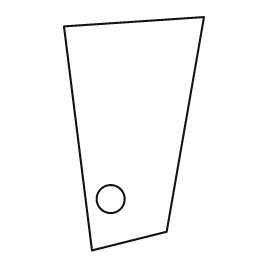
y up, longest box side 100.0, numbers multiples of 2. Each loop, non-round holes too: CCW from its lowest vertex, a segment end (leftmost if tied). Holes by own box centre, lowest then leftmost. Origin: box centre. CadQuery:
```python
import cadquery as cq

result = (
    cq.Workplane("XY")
    .moveTo(-18.0, -50.0)
    .lineTo(14.0, -42.0)
    .lineTo(30.0, 50.0)
    .lineTo(-30.0, 46.0)
    .close()
    .moveTo(-10.0, -28.0)
    .circle(6.0)
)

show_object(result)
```